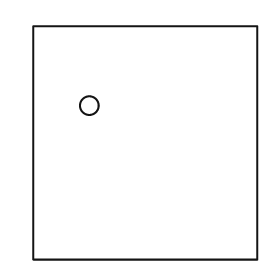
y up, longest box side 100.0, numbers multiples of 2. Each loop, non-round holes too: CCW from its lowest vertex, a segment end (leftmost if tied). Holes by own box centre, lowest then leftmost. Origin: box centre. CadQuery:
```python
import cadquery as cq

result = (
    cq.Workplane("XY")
    .moveTo(-48.0, -50.0)
    .lineTo(48.0, -50.0)
    .lineTo(48.0, 50.0)
    .lineTo(-48.0, 50.0)
    .close()
    .moveTo(-24.0, 16.0)
    .circle(4.0)
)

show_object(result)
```